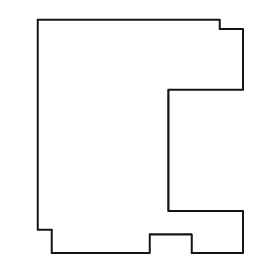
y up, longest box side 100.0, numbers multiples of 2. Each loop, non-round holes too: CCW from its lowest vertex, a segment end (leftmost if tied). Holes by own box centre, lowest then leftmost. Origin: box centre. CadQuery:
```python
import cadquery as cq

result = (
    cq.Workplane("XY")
    .moveTo(-38.0, -50.0)
    .lineTo(4.0, -50.0)
    .lineTo(4.0, -42.0)
    .lineTo(22.0, -42.0)
    .lineTo(22.0, -50.0)
    .lineTo(44.0, -50.0)
    .lineTo(44.0, -32.0)
    .lineTo(12.0, -32.0)
    .lineTo(12.0, 20.0)
    .lineTo(44.0, 20.0)
    .lineTo(44.0, 46.0)
    .lineTo(34.0, 46.0)
    .lineTo(34.0, 50.0)
    .lineTo(-44.0, 50.0)
    .lineTo(-44.0, -40.0)
    .lineTo(-38.0, -40.0)
    .close()
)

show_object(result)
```